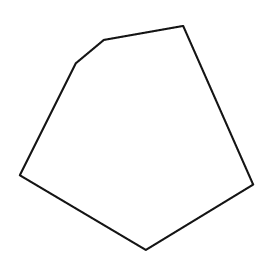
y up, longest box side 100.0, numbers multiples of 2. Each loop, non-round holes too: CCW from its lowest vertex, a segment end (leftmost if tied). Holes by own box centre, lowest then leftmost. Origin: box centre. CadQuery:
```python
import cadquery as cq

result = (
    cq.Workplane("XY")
    .moveTo(4.0, -48.0)
    .lineTo(50.0, -20.0)
    .lineTo(20.0, 48.0)
    .lineTo(-14.0, 42.0)
    .lineTo(-26.0, 32.0)
    .lineTo(-50.0, -16.0)
    .close()
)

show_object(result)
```